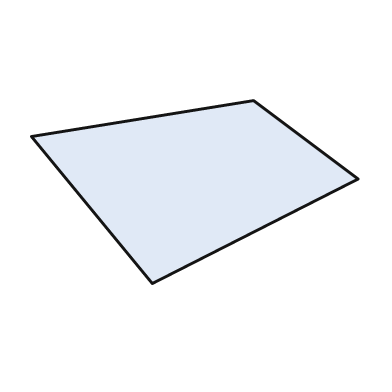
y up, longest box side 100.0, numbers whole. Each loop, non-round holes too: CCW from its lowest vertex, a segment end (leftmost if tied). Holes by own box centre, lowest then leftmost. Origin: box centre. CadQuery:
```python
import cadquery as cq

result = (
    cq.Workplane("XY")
    .moveTo(-13.0, -28.0)
    .lineTo(50.0, 4.0)
    .lineTo(18.0, 28.0)
    .lineTo(-50.0, 17.0)
    .close()
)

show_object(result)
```